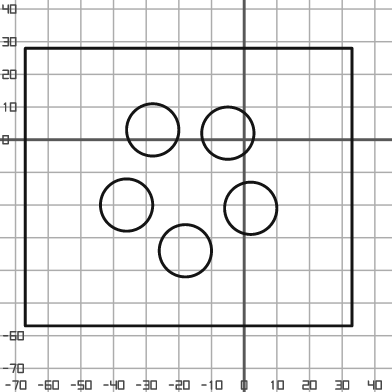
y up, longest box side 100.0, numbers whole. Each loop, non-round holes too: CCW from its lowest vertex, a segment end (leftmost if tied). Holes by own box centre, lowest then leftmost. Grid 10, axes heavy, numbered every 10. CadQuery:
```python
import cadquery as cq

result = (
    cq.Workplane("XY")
    .moveTo(-67.0, -57.0)
    .lineTo(33.0, -57.0)
    .lineTo(33.0, 28.0)
    .lineTo(-67.0, 28.0)
    .close()
    .moveTo(-18.0, -34.0)
    .circle(8.0)
    .moveTo(2.0, -21.0)
    .circle(8.0)
    .moveTo(-36.0, -20.0)
    .circle(8.0)
    .moveTo(-5.0, 2.0)
    .circle(8.0)
    .moveTo(-28.0, 3.0)
    .circle(8.0)
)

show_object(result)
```